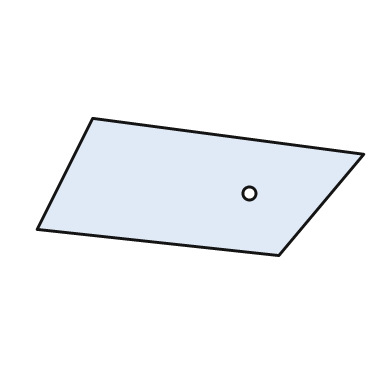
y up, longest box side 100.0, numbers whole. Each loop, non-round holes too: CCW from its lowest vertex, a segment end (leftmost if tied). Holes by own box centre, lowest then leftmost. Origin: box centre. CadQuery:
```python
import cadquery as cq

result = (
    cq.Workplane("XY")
    .moveTo(24.0, -21.0)
    .lineTo(50.0, 10.0)
    .lineTo(-33.0, 21.0)
    .lineTo(-50.0, -13.0)
    .close()
    .moveTo(15.0, -2.0)
    .circle(2.0)
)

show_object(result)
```